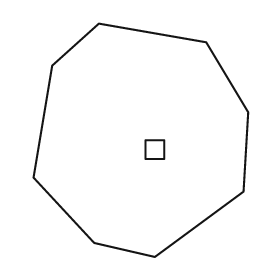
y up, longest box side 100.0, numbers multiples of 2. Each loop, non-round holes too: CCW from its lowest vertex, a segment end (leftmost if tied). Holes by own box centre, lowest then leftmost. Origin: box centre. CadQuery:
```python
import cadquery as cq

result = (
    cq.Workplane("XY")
    .moveTo(6.0, -50.0)
    .lineTo(44.0, -22.0)
    .lineTo(46.0, 12.0)
    .lineTo(28.0, 42.0)
    .lineTo(-18.0, 50.0)
    .lineTo(-38.0, 32.0)
    .lineTo(-46.0, -16.0)
    .lineTo(-20.0, -44.0)
    .close()
    .moveTo(2.0, -8.0)
    .lineTo(10.0, -8.0)
    .lineTo(10.0, 0.0)
    .lineTo(2.0, 0.0)
    .close()
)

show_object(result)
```